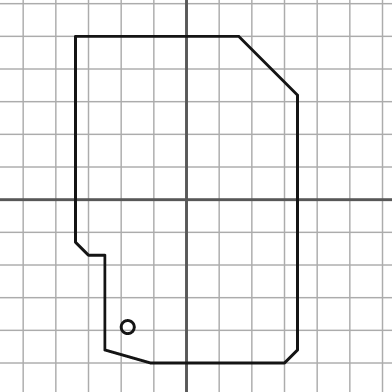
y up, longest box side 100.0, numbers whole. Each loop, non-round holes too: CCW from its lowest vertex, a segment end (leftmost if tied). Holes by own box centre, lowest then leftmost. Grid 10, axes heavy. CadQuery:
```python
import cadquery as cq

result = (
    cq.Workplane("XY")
    .moveTo(-11.0, -50.0)
    .lineTo(30.0, -50.0)
    .lineTo(34.0, -46.0)
    .lineTo(34.0, 32.0)
    .lineTo(16.0, 50.0)
    .lineTo(-34.0, 50.0)
    .lineTo(-34.0, -13.0)
    .lineTo(-30.0, -17.0)
    .lineTo(-25.0, -17.0)
    .lineTo(-25.0, -46.0)
    .close()
    .moveTo(-18.0, -39.0)
    .circle(2.0)
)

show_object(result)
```